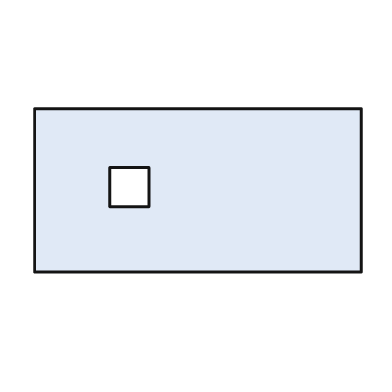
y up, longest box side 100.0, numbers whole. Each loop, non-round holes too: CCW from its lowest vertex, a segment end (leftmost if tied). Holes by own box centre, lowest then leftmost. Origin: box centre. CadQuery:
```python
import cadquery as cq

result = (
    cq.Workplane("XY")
    .moveTo(-50.0, -25.0)
    .lineTo(50.0, -25.0)
    .lineTo(50.0, 25.0)
    .lineTo(-50.0, 25.0)
    .close()
    .moveTo(-27.0, -5.0)
    .lineTo(-15.0, -5.0)
    .lineTo(-15.0, 7.0)
    .lineTo(-27.0, 7.0)
    .close()
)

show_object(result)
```